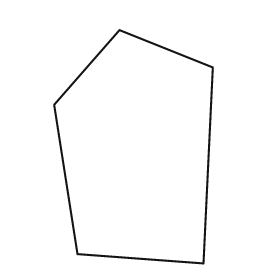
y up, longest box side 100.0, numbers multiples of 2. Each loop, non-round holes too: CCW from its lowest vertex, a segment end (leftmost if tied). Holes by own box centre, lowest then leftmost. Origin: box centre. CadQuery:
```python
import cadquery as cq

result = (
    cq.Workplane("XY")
    .moveTo(30.0, -50.0)
    .lineTo(34.0, 34.0)
    .lineTo(-6.0, 50.0)
    .lineTo(-34.0, 18.0)
    .lineTo(-24.0, -46.0)
    .close()
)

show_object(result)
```